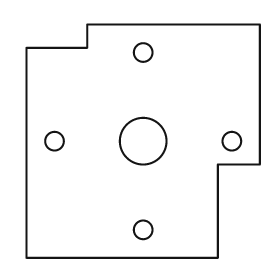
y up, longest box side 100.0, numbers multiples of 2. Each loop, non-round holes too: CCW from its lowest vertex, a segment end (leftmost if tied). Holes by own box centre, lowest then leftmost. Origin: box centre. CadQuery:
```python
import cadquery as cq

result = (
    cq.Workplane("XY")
    .moveTo(-50.0, -50.0)
    .lineTo(32.0, -50.0)
    .lineTo(32.0, -10.0)
    .lineTo(50.0, -10.0)
    .lineTo(50.0, 50.0)
    .lineTo(-24.0, 50.0)
    .lineTo(-24.0, 40.0)
    .lineTo(-50.0, 40.0)
    .close()
    .moveTo(0.0, -38.0)
    .circle(4.0)
    .moveTo(-38.0, 0.0)
    .circle(4.0)
    .moveTo(0.0, 0.0)
    .circle(10.0)
    .moveTo(38.0, 0.0)
    .circle(4.0)
    .moveTo(0.0, 38.0)
    .circle(4.0)
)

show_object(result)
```